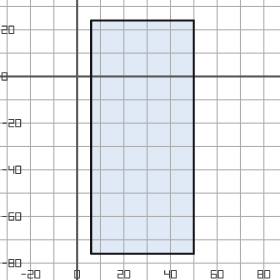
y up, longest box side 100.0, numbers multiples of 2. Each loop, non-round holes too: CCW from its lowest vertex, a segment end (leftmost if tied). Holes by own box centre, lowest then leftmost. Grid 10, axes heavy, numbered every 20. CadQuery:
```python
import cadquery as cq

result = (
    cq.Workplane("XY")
    .moveTo(6.0, -76.0)
    .lineTo(50.0, -76.0)
    .lineTo(50.0, 24.0)
    .lineTo(6.0, 24.0)
    .close()
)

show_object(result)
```